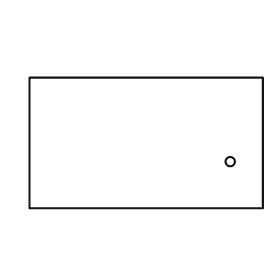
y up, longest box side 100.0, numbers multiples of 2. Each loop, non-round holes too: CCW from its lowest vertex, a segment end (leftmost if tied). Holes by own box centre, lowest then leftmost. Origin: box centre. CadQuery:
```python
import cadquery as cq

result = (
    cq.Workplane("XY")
    .moveTo(-50.0, -28.0)
    .lineTo(50.0, -28.0)
    .lineTo(50.0, 28.0)
    .lineTo(-50.0, 28.0)
    .close()
    .moveTo(36.0, -8.0)
    .circle(2.0)
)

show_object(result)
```